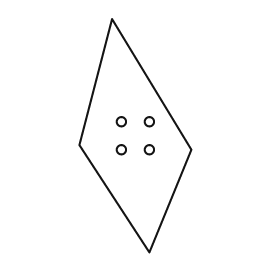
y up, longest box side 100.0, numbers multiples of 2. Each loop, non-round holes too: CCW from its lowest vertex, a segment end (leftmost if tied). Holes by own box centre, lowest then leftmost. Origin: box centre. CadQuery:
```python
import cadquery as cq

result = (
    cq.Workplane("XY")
    .moveTo(6.0, -50.0)
    .lineTo(24.0, -6.0)
    .lineTo(-10.0, 50.0)
    .lineTo(-24.0, -4.0)
    .close()
    .moveTo(-6.0, -6.0)
    .circle(2.0)
    .moveTo(6.0, -6.0)
    .circle(2.0)
    .moveTo(-6.0, 6.0)
    .circle(2.0)
    .moveTo(6.0, 6.0)
    .circle(2.0)
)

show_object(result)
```